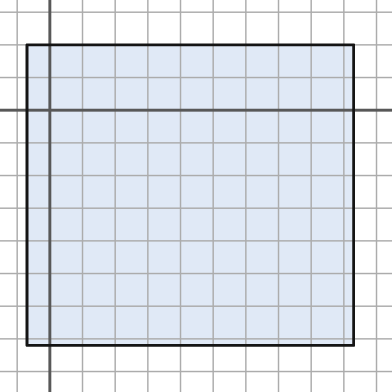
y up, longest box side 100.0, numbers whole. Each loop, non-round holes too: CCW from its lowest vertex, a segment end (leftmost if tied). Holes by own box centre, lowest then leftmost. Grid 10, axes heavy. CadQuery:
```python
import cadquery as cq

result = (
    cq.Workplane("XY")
    .moveTo(-7.0, -72.0)
    .lineTo(93.0, -72.0)
    .lineTo(93.0, 20.0)
    .lineTo(-7.0, 20.0)
    .close()
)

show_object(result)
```